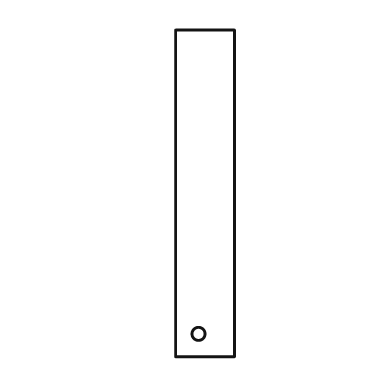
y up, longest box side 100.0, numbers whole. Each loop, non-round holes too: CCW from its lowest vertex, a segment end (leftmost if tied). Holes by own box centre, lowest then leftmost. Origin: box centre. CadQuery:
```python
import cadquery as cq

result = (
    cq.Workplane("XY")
    .moveTo(-9.0, -50.0)
    .lineTo(9.0, -50.0)
    .lineTo(9.0, 50.0)
    .lineTo(-9.0, 50.0)
    .close()
    .moveTo(-2.0, -43.0)
    .circle(2.0)
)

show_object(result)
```